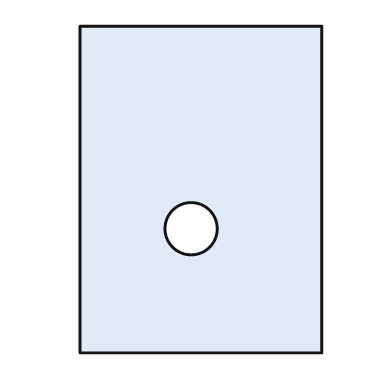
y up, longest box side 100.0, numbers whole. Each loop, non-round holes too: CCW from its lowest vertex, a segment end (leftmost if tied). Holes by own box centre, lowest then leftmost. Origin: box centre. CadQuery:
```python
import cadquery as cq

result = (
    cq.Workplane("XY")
    .moveTo(-37.0, -50.0)
    .lineTo(37.0, -50.0)
    .lineTo(37.0, 50.0)
    .lineTo(-37.0, 50.0)
    .close()
    .moveTo(-3.0, -12.0)
    .circle(8.0)
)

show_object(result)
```